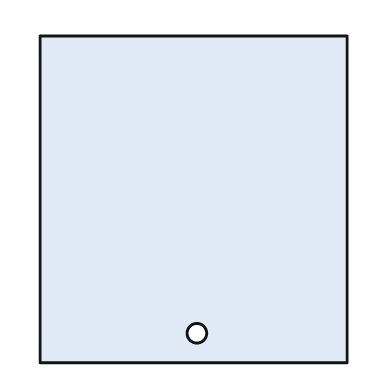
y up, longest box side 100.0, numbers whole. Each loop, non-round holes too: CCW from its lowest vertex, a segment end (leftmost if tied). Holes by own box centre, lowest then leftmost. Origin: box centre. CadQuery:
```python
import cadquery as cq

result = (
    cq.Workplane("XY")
    .moveTo(-47.0, -50.0)
    .lineTo(47.0, -50.0)
    .lineTo(47.0, 50.0)
    .lineTo(-47.0, 50.0)
    .close()
    .moveTo(1.0, -41.0)
    .circle(3.0)
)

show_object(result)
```